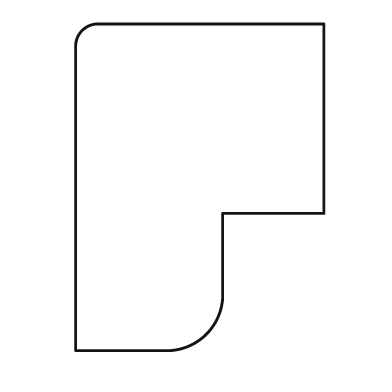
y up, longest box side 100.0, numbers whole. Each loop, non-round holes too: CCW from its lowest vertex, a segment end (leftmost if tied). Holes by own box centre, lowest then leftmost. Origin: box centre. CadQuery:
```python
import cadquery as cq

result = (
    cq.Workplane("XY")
    .moveTo(-38.0, -50.0)
    .lineTo(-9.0, -50.0)
    .threePointArc((2.0, -45.0), (7.0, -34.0))
    .lineTo(7.0, -8.0)
    .lineTo(38.0, -8.0)
    .lineTo(38.0, 50.0)
    .lineTo(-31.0, 50.0)
    .threePointArc((-36.0, 48.0), (-38.0, 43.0))
    .close()
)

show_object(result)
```